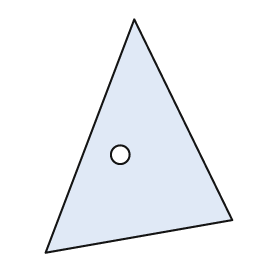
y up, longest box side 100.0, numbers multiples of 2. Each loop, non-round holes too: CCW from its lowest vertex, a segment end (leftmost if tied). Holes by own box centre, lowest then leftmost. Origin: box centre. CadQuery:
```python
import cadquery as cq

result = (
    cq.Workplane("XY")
    .moveTo(-40.0, -50.0)
    .lineTo(40.0, -36.0)
    .lineTo(-2.0, 50.0)
    .close()
    .moveTo(-8.0, -8.0)
    .circle(4.0)
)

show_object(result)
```